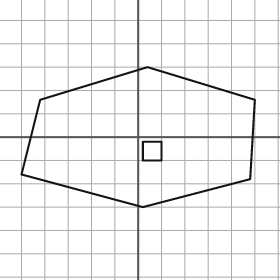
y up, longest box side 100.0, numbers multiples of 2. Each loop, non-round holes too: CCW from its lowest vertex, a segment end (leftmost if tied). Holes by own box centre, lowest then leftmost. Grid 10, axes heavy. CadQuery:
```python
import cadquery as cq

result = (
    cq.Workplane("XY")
    .moveTo(2.0, -30.0)
    .lineTo(48.0, -18.0)
    .lineTo(50.0, 16.0)
    .lineTo(4.0, 30.0)
    .lineTo(-42.0, 16.0)
    .lineTo(-50.0, -16.0)
    .close()
    .moveTo(2.0, -10.0)
    .lineTo(10.0, -10.0)
    .lineTo(10.0, -2.0)
    .lineTo(2.0, -2.0)
    .close()
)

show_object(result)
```